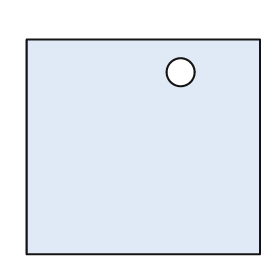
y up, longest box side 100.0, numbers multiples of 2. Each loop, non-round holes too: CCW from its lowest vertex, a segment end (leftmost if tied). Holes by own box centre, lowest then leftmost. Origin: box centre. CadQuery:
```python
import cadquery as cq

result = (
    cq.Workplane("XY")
    .moveTo(-50.0, -46.0)
    .lineTo(50.0, -46.0)
    .lineTo(50.0, 46.0)
    .lineTo(-50.0, 46.0)
    .close()
    .moveTo(16.0, 32.0)
    .circle(6.0)
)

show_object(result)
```